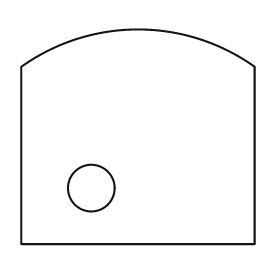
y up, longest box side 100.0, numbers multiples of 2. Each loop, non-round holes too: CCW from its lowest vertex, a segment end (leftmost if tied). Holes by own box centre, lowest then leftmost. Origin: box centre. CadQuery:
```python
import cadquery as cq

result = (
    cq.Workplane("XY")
    .moveTo(-50.0, -46.0)
    .lineTo(50.0, -46.0)
    .lineTo(50.0, 30.0)
    .threePointArc((0.0, 46.0), (-50.0, 30.0))
    .close()
    .moveTo(-20.0, -22.0)
    .circle(10.0)
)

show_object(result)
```